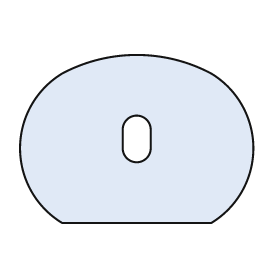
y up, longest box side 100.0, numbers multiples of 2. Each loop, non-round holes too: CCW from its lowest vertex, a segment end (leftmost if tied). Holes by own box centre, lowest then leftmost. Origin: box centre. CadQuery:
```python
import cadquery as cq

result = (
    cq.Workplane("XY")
    .moveTo(-32.0, -36.0)
    .lineTo(32.0, -36.0)
    .threePointArc((50.0, -4.0), (32.0, 28.0))
    .threePointArc((0.0, 36.0), (-32.0, 28.0))
    .threePointArc((-50.0, -4.0), (-32.0, -36.0))
    .close()
    .moveTo(-6.0, -4.0)
    .threePointArc((0.0, -10.0), (6.0, -4.0))
    .lineTo(6.0, 4.0)
    .threePointArc((0.0, 10.0), (-6.0, 4.0))
    .close()
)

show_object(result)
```